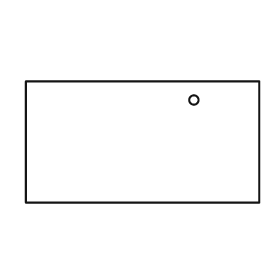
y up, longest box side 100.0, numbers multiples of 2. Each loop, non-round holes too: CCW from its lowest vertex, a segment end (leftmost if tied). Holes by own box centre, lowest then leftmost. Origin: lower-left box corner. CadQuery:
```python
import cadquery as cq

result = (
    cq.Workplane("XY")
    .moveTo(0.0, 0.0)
    .lineTo(100.0, 0.0)
    .lineTo(100.0, 52.0)
    .lineTo(0.0, 52.0)
    .close()
    .moveTo(72.0, 44.0)
    .circle(2.0)
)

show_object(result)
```